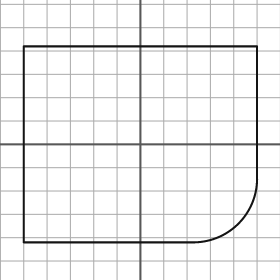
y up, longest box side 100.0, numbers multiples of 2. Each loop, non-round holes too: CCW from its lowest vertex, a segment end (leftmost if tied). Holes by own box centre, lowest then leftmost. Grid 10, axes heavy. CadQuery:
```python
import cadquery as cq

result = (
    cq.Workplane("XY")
    .moveTo(-50.0, -42.0)
    .lineTo(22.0, -42.0)
    .threePointArc((42.0, -34.0), (50.0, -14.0))
    .lineTo(50.0, 42.0)
    .lineTo(-50.0, 42.0)
    .close()
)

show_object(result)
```